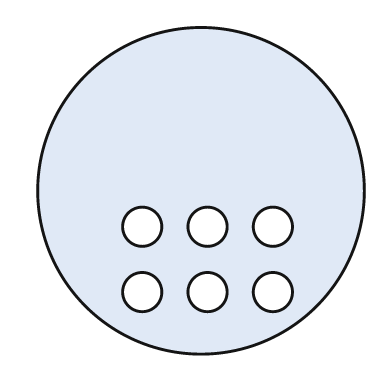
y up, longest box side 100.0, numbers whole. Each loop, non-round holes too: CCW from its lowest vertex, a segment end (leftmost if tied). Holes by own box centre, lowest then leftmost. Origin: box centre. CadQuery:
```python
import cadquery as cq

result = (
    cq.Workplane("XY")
    .moveTo(0.0, 0.0)
    .circle(50.0)
    .moveTo(-18.0, -31.0)
    .circle(6.0)
    .moveTo(2.0, -31.0)
    .circle(6.0)
    .moveTo(22.0, -31.0)
    .circle(6.0)
    .moveTo(-18.0, -11.0)
    .circle(6.0)
    .moveTo(2.0, -11.0)
    .circle(6.0)
    .moveTo(22.0, -11.0)
    .circle(6.0)
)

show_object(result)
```